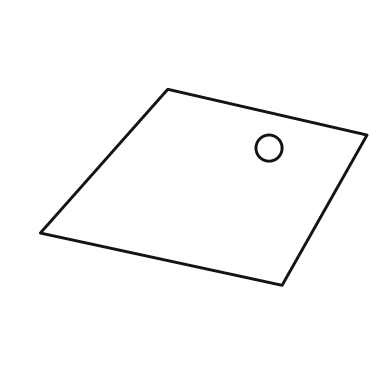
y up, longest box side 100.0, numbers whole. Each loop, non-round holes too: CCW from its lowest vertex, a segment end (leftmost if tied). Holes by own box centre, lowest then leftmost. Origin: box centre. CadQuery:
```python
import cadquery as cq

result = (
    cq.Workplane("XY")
    .moveTo(24.0, -30.0)
    .lineTo(50.0, 16.0)
    .lineTo(-11.0, 30.0)
    .lineTo(-50.0, -14.0)
    .close()
    .moveTo(20.0, 12.0)
    .circle(4.0)
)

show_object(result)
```